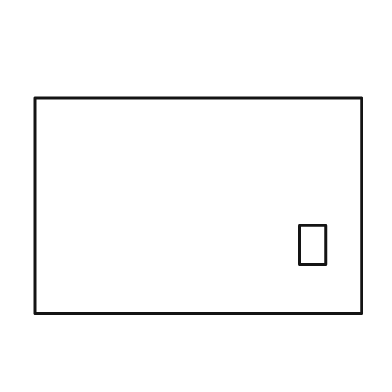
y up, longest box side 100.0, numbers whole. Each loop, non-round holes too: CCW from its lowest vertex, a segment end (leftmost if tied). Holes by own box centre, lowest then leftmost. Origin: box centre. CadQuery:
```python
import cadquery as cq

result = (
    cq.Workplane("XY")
    .moveTo(-50.0, -33.0)
    .lineTo(50.0, -33.0)
    .lineTo(50.0, 33.0)
    .lineTo(-50.0, 33.0)
    .close()
    .moveTo(31.0, -18.0)
    .lineTo(39.0, -18.0)
    .lineTo(39.0, -6.0)
    .lineTo(31.0, -6.0)
    .close()
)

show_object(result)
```